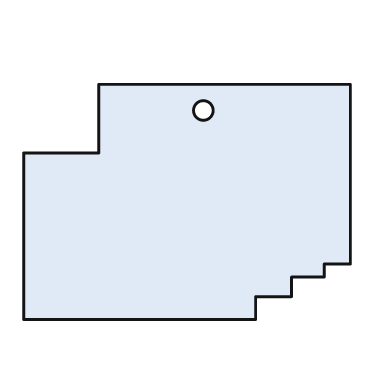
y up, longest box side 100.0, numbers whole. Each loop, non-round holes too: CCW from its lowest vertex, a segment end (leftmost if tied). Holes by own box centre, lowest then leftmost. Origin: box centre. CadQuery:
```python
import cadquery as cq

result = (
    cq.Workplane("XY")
    .moveTo(-50.0, -36.0)
    .lineTo(21.0, -36.0)
    .lineTo(21.0, -29.0)
    .lineTo(32.0, -29.0)
    .lineTo(32.0, -23.0)
    .lineTo(42.0, -23.0)
    .lineTo(42.0, -19.0)
    .lineTo(50.0, -19.0)
    .lineTo(50.0, 36.0)
    .lineTo(-27.0, 36.0)
    .lineTo(-27.0, 15.0)
    .lineTo(-50.0, 15.0)
    .close()
    .moveTo(5.0, 28.0)
    .circle(3.0)
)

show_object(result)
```